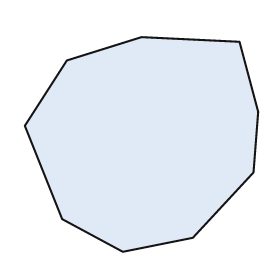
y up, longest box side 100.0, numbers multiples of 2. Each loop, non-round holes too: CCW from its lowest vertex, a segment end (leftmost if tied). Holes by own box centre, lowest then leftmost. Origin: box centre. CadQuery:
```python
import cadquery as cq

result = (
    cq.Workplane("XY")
    .moveTo(-8.0, -46.0)
    .lineTo(22.0, -40.0)
    .lineTo(48.0, -12.0)
    .lineTo(50.0, 14.0)
    .lineTo(42.0, 44.0)
    .lineTo(0.0, 46.0)
    .lineTo(-32.0, 36.0)
    .lineTo(-50.0, 8.0)
    .lineTo(-34.0, -32.0)
    .close()
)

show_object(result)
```